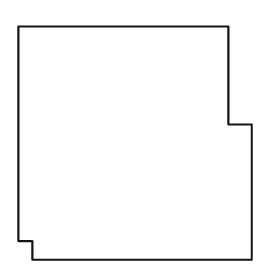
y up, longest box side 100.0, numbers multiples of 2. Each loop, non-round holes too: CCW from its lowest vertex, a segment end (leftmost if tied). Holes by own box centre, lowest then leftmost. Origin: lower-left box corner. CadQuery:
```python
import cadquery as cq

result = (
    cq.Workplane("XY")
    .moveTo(6.0, 0.0)
    .lineTo(100.0, 0.0)
    .lineTo(100.0, 58.0)
    .lineTo(90.0, 58.0)
    .lineTo(90.0, 100.0)
    .lineTo(0.0, 100.0)
    .lineTo(0.0, 8.0)
    .lineTo(6.0, 8.0)
    .close()
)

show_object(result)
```